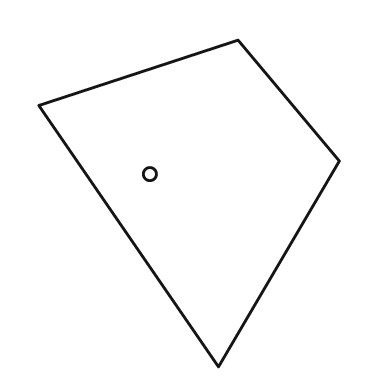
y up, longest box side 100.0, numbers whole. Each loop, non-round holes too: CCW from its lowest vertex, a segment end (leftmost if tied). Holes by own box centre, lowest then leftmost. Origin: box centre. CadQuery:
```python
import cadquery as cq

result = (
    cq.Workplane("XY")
    .moveTo(9.0, -50.0)
    .lineTo(46.0, 13.0)
    .lineTo(15.0, 50.0)
    .lineTo(-46.0, 30.0)
    .close()
    .moveTo(-12.0, 9.0)
    .circle(2.0)
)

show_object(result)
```